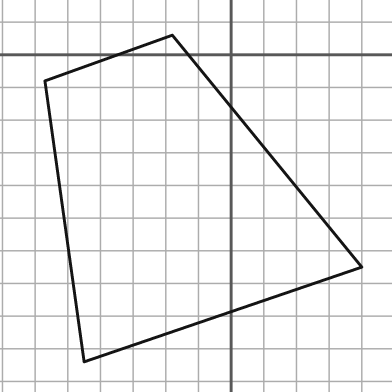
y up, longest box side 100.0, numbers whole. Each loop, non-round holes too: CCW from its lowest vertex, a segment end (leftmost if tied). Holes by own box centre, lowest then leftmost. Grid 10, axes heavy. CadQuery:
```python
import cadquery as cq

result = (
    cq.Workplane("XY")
    .moveTo(-45.0, -94.0)
    .lineTo(40.0, -65.0)
    .lineTo(-18.0, 6.0)
    .lineTo(-57.0, -8.0)
    .close()
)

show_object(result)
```